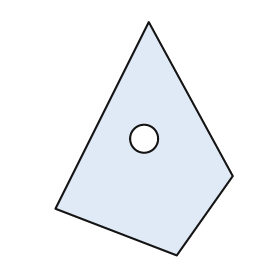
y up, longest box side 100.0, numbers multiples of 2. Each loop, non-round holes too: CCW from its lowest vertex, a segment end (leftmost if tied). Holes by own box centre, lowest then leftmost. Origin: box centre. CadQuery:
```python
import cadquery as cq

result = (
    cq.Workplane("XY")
    .moveTo(14.0, -50.0)
    .lineTo(38.0, -16.0)
    .lineTo(2.0, 50.0)
    .lineTo(-38.0, -30.0)
    .close()
    .moveTo(0.0, 0.0)
    .circle(6.0)
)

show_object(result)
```